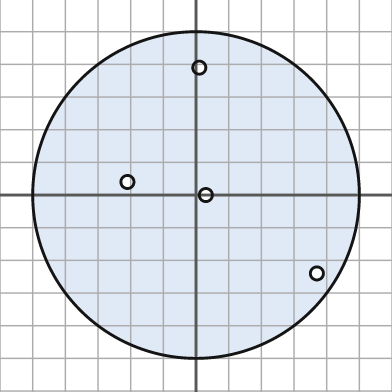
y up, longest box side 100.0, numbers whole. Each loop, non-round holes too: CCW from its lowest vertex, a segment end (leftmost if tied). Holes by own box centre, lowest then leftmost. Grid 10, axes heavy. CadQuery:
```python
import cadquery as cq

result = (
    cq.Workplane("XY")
    .moveTo(0.0, 0.0)
    .circle(50.0)
    .moveTo(37.0, -24.0)
    .circle(2.0)
    .moveTo(3.0, 0.0)
    .circle(2.0)
    .moveTo(-21.0, 4.0)
    .circle(2.0)
    .moveTo(1.0, 39.0)
    .circle(2.0)
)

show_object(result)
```